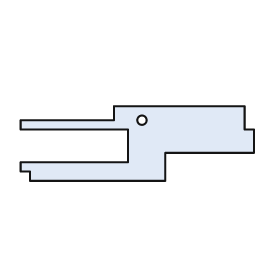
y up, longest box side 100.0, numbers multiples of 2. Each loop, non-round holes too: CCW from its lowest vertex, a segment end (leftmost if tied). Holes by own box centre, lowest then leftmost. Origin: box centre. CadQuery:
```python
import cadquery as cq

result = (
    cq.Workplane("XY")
    .moveTo(-46.0, -16.0)
    .lineTo(12.0, -16.0)
    .lineTo(12.0, -4.0)
    .lineTo(50.0, -4.0)
    .lineTo(50.0, 6.0)
    .lineTo(46.0, 6.0)
    .lineTo(46.0, 16.0)
    .lineTo(-10.0, 16.0)
    .lineTo(-10.0, 10.0)
    .lineTo(-50.0, 10.0)
    .lineTo(-50.0, 6.0)
    .lineTo(-4.0, 6.0)
    .lineTo(-4.0, -8.0)
    .lineTo(-50.0, -8.0)
    .lineTo(-50.0, -12.0)
    .lineTo(-46.0, -12.0)
    .close()
    .moveTo(2.0, 10.0)
    .circle(2.0)
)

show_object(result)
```